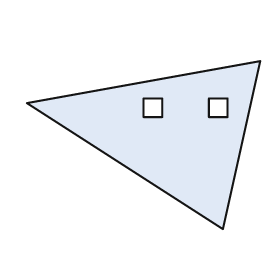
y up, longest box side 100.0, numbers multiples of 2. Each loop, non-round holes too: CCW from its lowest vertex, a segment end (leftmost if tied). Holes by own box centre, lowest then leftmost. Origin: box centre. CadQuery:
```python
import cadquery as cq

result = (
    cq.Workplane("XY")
    .moveTo(34.0, -36.0)
    .lineTo(50.0, 36.0)
    .lineTo(-50.0, 18.0)
    .close()
    .moveTo(0.0, 12.0)
    .lineTo(8.0, 12.0)
    .lineTo(8.0, 20.0)
    .lineTo(0.0, 20.0)
    .close()
    .moveTo(28.0, 12.0)
    .lineTo(36.0, 12.0)
    .lineTo(36.0, 20.0)
    .lineTo(28.0, 20.0)
    .close()
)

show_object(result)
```